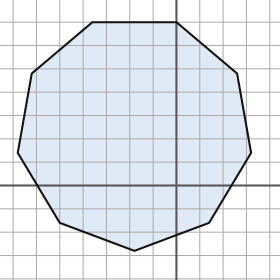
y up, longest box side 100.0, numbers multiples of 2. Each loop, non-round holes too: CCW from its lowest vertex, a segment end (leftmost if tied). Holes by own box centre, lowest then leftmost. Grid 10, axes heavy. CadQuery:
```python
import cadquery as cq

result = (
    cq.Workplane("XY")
    .moveTo(-18.0, -28.0)
    .lineTo(14.0, -16.0)
    .lineTo(32.0, 14.0)
    .lineTo(26.0, 48.0)
    .lineTo(0.0, 70.0)
    .lineTo(-36.0, 70.0)
    .lineTo(-62.0, 48.0)
    .lineTo(-68.0, 14.0)
    .lineTo(-50.0, -16.0)
    .close()
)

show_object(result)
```